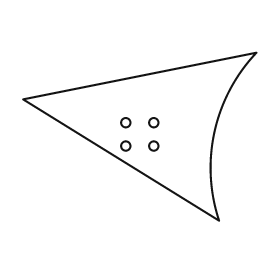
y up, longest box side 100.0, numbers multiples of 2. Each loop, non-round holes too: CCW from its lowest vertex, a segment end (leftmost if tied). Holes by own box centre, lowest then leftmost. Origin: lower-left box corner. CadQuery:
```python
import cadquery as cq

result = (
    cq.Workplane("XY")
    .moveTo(84.0, 0.0)
    .threePointArc((82.0, 38.0), (100.0, 72.0))
    .lineTo(0.0, 52.0)
    .close()
    .moveTo(44.0, 32.0)
    .circle(2.0)
    .moveTo(56.0, 32.0)
    .circle(2.0)
    .moveTo(44.0, 42.0)
    .circle(2.0)
    .moveTo(56.0, 42.0)
    .circle(2.0)
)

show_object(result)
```